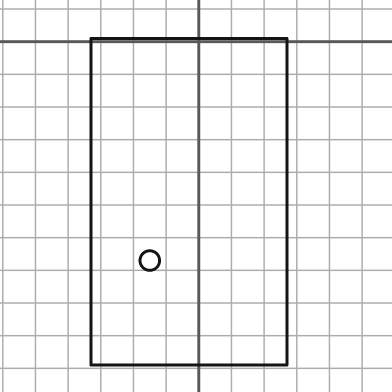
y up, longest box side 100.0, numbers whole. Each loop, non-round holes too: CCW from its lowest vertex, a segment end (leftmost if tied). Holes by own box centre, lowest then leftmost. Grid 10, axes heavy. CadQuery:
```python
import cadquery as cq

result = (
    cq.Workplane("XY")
    .moveTo(-33.0, -99.0)
    .lineTo(27.0, -99.0)
    .lineTo(27.0, 1.0)
    .lineTo(-33.0, 1.0)
    .close()
    .moveTo(-15.0, -67.0)
    .circle(3.0)
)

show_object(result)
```